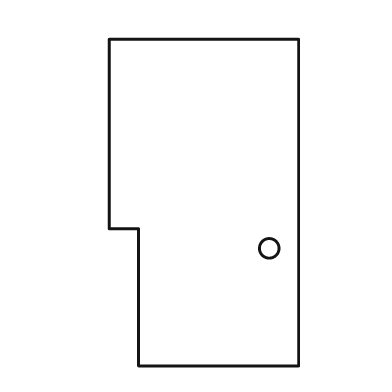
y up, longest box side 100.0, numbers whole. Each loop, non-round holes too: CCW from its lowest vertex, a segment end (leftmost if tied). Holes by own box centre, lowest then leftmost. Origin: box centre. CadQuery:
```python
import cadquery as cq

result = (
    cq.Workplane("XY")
    .moveTo(-20.0, -50.0)
    .lineTo(29.0, -50.0)
    .lineTo(29.0, 50.0)
    .lineTo(-29.0, 50.0)
    .lineTo(-29.0, -8.0)
    .lineTo(-20.0, -8.0)
    .close()
    .moveTo(20.0, -14.0)
    .circle(3.0)
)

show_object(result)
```